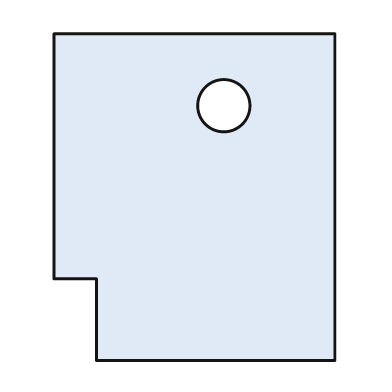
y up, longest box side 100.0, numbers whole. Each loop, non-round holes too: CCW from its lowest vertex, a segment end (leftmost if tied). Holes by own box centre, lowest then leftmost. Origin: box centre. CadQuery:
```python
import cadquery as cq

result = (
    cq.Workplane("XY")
    .moveTo(-30.0, -50.0)
    .lineTo(43.0, -50.0)
    .lineTo(43.0, 50.0)
    .lineTo(-43.0, 50.0)
    .lineTo(-43.0, -25.0)
    .lineTo(-30.0, -25.0)
    .close()
    .moveTo(9.0, 28.0)
    .circle(8.0)
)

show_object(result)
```